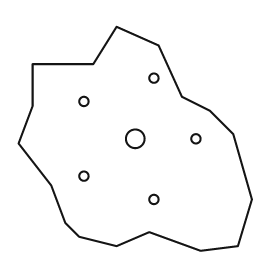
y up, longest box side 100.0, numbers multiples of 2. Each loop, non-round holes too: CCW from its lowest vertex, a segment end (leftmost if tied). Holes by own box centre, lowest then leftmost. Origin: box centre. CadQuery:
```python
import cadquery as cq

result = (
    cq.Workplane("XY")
    .moveTo(28.0, -48.0)
    .lineTo(44.0, -46.0)
    .lineTo(50.0, -26.0)
    .lineTo(42.0, 2.0)
    .lineTo(32.0, 12.0)
    .lineTo(20.0, 18.0)
    .lineTo(10.0, 40.0)
    .lineTo(-8.0, 48.0)
    .lineTo(-18.0, 32.0)
    .lineTo(-44.0, 32.0)
    .lineTo(-44.0, 14.0)
    .lineTo(-50.0, -2.0)
    .lineTo(-36.0, -20.0)
    .lineTo(-30.0, -36.0)
    .lineTo(-24.0, -42.0)
    .lineTo(-8.0, -46.0)
    .lineTo(6.0, -40.0)
    .close()
    .moveTo(8.0, -26.0)
    .circle(2.0)
    .moveTo(-22.0, -16.0)
    .circle(2.0)
    .moveTo(0.0, 0.0)
    .circle(4.0)
    .moveTo(26.0, 0.0)
    .circle(2.0)
    .moveTo(-22.0, 16.0)
    .circle(2.0)
    .moveTo(8.0, 26.0)
    .circle(2.0)
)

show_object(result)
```